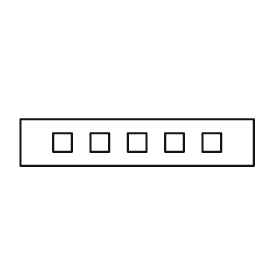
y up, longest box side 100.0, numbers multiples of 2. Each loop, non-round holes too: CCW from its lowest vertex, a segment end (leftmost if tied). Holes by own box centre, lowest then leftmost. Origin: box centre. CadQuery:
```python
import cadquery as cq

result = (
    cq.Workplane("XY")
    .moveTo(-50.0, -10.0)
    .lineTo(50.0, -10.0)
    .lineTo(50.0, 10.0)
    .lineTo(-50.0, 10.0)
    .close()
    .moveTo(-36.0, -4.0)
    .lineTo(-28.0, -4.0)
    .lineTo(-28.0, 4.0)
    .lineTo(-36.0, 4.0)
    .close()
    .moveTo(-20.0, -4.0)
    .lineTo(-12.0, -4.0)
    .lineTo(-12.0, 4.0)
    .lineTo(-20.0, 4.0)
    .close()
    .moveTo(-4.0, -4.0)
    .lineTo(4.0, -4.0)
    .lineTo(4.0, 4.0)
    .lineTo(-4.0, 4.0)
    .close()
    .moveTo(12.0, -4.0)
    .lineTo(20.0, -4.0)
    .lineTo(20.0, 4.0)
    .lineTo(12.0, 4.0)
    .close()
    .moveTo(28.0, -4.0)
    .lineTo(36.0, -4.0)
    .lineTo(36.0, 4.0)
    .lineTo(28.0, 4.0)
    .close()
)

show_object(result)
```